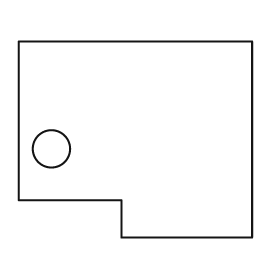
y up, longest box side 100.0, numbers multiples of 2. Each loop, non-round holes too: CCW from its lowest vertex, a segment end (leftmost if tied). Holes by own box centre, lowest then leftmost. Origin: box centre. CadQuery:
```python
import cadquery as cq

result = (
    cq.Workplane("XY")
    .moveTo(-6.0, -42.0)
    .lineTo(50.0, -42.0)
    .lineTo(50.0, 42.0)
    .lineTo(-50.0, 42.0)
    .lineTo(-50.0, -26.0)
    .lineTo(-6.0, -26.0)
    .close()
    .moveTo(-36.0, -4.0)
    .circle(8.0)
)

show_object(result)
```